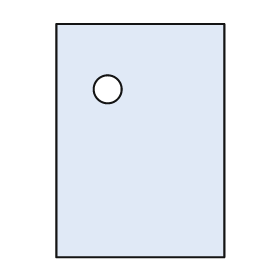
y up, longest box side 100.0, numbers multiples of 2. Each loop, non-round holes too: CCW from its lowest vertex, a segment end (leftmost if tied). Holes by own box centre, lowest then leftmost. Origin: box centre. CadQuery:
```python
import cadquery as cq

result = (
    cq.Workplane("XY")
    .moveTo(-36.0, -50.0)
    .lineTo(36.0, -50.0)
    .lineTo(36.0, 50.0)
    .lineTo(-36.0, 50.0)
    .close()
    .moveTo(-14.0, 22.0)
    .circle(6.0)
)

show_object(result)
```